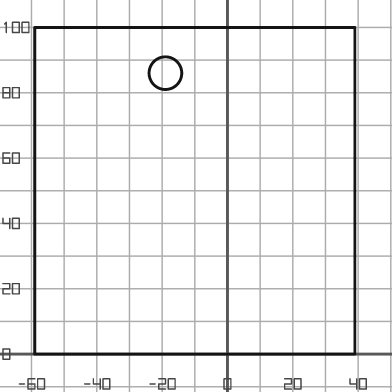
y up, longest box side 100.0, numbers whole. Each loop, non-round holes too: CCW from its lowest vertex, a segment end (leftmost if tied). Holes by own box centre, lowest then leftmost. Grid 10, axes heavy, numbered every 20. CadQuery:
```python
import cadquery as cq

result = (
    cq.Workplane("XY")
    .moveTo(-59.0, 0.0)
    .lineTo(39.0, 0.0)
    .lineTo(39.0, 100.0)
    .lineTo(-59.0, 100.0)
    .close()
    .moveTo(-19.0, 86.0)
    .circle(5.0)
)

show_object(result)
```